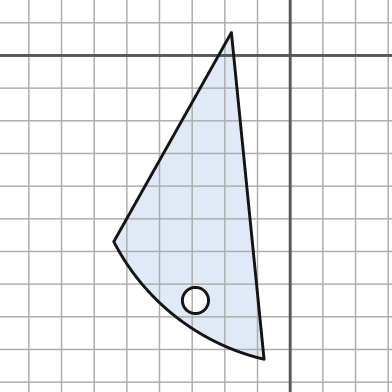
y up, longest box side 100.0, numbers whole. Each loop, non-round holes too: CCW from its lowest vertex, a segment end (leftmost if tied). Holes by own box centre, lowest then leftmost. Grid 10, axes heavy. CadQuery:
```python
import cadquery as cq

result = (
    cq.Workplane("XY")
    .moveTo(-8.0, -93.0)
    .lineTo(-18.0, 7.0)
    .lineTo(-54.0, -57.0)
    .threePointArc((-35.0, -80.0), (-8.0, -93.0))
    .close()
    .moveTo(-29.0, -75.0)
    .circle(4.0)
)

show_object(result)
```